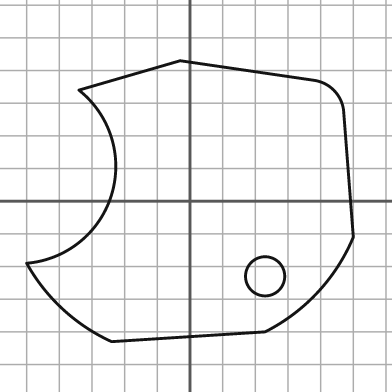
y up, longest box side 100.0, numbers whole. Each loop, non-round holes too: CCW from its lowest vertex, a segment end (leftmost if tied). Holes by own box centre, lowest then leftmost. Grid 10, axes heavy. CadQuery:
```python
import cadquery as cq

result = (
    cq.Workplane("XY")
    .moveTo(-24.0, -43.0)
    .lineTo(23.0, -40.0)
    .threePointArc((39.0, -28.0), (50.0, -11.0))
    .lineTo(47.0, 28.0)
    .threePointArc((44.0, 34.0), (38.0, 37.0))
    .lineTo(-3.0, 43.0)
    .lineTo(-34.0, 34.0)
    .threePointArc((-24.0, 2.0), (-50.0, -19.0))
    .threePointArc((-39.0, -33.0), (-24.0, -43.0))
    .close()
    .moveTo(23.0, -23.0)
    .circle(6.0)
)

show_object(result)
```